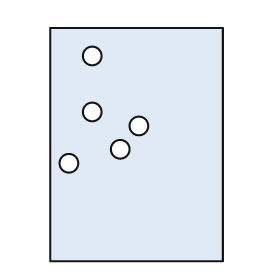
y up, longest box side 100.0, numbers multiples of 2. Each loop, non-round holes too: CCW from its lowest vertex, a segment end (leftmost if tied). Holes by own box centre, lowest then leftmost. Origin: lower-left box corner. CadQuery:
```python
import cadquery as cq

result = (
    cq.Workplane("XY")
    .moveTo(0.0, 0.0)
    .lineTo(74.0, 0.0)
    .lineTo(74.0, 100.0)
    .lineTo(0.0, 100.0)
    .close()
    .moveTo(8.0, 42.0)
    .circle(4.0)
    .moveTo(30.0, 48.0)
    .circle(4.0)
    .moveTo(38.0, 58.0)
    .circle(4.0)
    .moveTo(18.0, 64.0)
    .circle(4.0)
    .moveTo(18.0, 88.0)
    .circle(4.0)
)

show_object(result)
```